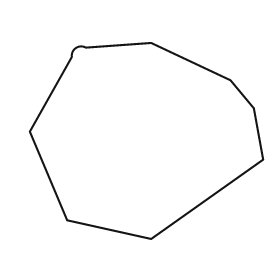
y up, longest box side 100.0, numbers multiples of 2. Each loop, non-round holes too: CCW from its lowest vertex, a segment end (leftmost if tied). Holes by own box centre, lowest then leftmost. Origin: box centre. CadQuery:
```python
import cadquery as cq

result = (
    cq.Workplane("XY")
    .moveTo(2.0, -42.0)
    .lineTo(50.0, -8.0)
    .lineTo(46.0, 14.0)
    .lineTo(36.0, 26.0)
    .lineTo(2.0, 42.0)
    .lineTo(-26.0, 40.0)
    .threePointArc((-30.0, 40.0), (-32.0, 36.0))
    .lineTo(-50.0, 4.0)
    .lineTo(-34.0, -34.0)
    .close()
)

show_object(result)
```